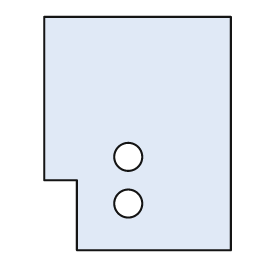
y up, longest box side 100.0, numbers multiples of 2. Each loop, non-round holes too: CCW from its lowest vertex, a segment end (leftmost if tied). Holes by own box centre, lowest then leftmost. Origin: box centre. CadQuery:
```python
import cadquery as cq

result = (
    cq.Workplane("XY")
    .moveTo(-26.0, -50.0)
    .lineTo(40.0, -50.0)
    .lineTo(40.0, 50.0)
    .lineTo(-40.0, 50.0)
    .lineTo(-40.0, -20.0)
    .lineTo(-26.0, -20.0)
    .close()
    .moveTo(-4.0, -30.0)
    .circle(6.0)
    .moveTo(-4.0, -10.0)
    .circle(6.0)
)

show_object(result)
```